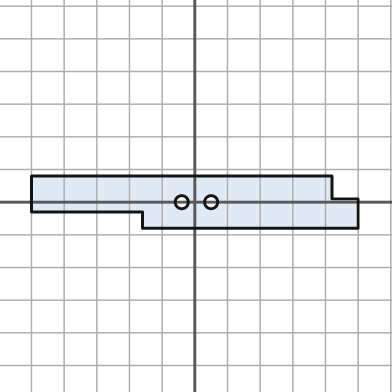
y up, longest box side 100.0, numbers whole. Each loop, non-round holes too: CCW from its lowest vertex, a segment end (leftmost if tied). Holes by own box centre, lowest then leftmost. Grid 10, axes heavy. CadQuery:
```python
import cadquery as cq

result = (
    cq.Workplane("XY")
    .moveTo(-16.0, -8.0)
    .lineTo(50.0, -8.0)
    .lineTo(50.0, 1.0)
    .lineTo(42.0, 1.0)
    .lineTo(42.0, 8.0)
    .lineTo(-50.0, 8.0)
    .lineTo(-50.0, -3.0)
    .lineTo(-16.0, -3.0)
    .close()
    .moveTo(-4.0, 0.0)
    .circle(2.0)
    .moveTo(5.0, 0.0)
    .circle(2.0)
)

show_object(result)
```